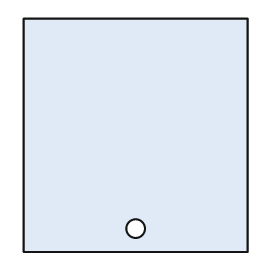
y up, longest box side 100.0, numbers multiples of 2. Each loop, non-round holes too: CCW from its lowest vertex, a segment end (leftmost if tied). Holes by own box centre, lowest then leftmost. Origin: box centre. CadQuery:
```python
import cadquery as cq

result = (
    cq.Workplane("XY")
    .moveTo(-48.0, -50.0)
    .lineTo(48.0, -50.0)
    .lineTo(48.0, 50.0)
    .lineTo(-48.0, 50.0)
    .close()
    .moveTo(0.0, -40.0)
    .circle(4.0)
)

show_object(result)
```